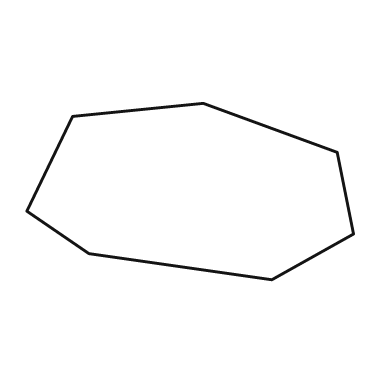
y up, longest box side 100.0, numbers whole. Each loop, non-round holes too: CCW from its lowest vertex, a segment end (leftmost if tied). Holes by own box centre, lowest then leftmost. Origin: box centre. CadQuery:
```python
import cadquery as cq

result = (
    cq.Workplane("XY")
    .moveTo(25.0, -27.0)
    .lineTo(50.0, -13.0)
    .lineTo(45.0, 12.0)
    .lineTo(4.0, 27.0)
    .lineTo(-36.0, 23.0)
    .lineTo(-50.0, -6.0)
    .lineTo(-31.0, -19.0)
    .close()
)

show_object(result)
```